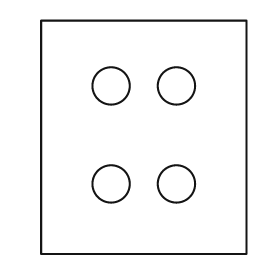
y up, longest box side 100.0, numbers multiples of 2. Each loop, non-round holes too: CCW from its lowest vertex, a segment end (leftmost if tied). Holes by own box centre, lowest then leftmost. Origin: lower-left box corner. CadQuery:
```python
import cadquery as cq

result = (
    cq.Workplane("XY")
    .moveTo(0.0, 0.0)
    .lineTo(88.0, 0.0)
    .lineTo(88.0, 100.0)
    .lineTo(0.0, 100.0)
    .close()
    .moveTo(30.0, 30.0)
    .circle(8.0)
    .moveTo(58.0, 30.0)
    .circle(8.0)
    .moveTo(30.0, 72.0)
    .circle(8.0)
    .moveTo(58.0, 72.0)
    .circle(8.0)
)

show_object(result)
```